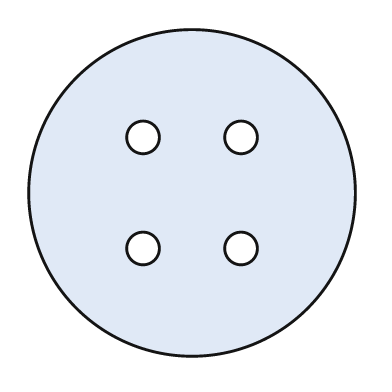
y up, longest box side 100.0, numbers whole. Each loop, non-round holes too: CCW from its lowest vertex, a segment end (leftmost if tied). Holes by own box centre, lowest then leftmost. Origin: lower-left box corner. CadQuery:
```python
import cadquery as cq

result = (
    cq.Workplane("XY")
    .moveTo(50.0, 50.0)
    .circle(50.0)
    .moveTo(35.0, 33.0)
    .circle(5.0)
    .moveTo(65.0, 33.0)
    .circle(5.0)
    .moveTo(35.0, 67.0)
    .circle(5.0)
    .moveTo(65.0, 67.0)
    .circle(5.0)
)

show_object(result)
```